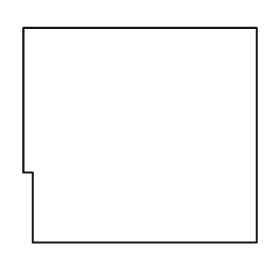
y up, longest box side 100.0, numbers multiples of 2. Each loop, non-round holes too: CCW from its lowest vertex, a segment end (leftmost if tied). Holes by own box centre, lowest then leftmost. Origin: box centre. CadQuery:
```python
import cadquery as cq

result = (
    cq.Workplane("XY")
    .moveTo(-46.0, -46.0)
    .lineTo(50.0, -46.0)
    .lineTo(50.0, 46.0)
    .lineTo(-50.0, 46.0)
    .lineTo(-50.0, -16.0)
    .lineTo(-46.0, -16.0)
    .close()
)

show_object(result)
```